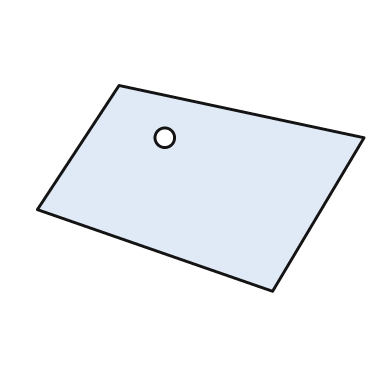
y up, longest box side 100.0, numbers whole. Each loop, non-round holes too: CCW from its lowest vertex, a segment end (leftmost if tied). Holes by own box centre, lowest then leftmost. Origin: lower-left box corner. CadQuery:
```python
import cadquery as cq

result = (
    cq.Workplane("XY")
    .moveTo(72.0, 0.0)
    .lineTo(100.0, 47.0)
    .lineTo(25.0, 63.0)
    .lineTo(0.0, 25.0)
    .close()
    .moveTo(39.0, 47.0)
    .circle(3.0)
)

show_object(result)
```